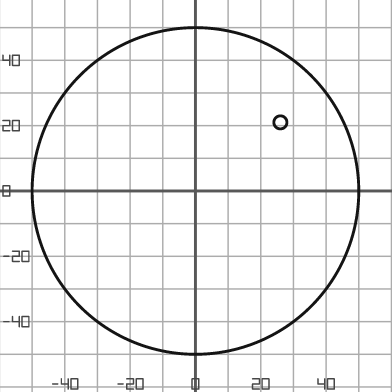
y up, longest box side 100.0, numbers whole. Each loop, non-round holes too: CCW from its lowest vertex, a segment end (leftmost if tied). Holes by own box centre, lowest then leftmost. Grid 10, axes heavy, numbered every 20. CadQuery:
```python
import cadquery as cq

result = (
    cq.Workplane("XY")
    .moveTo(0.0, 0.0)
    .circle(50.0)
    .moveTo(26.0, 21.0)
    .circle(2.0)
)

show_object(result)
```